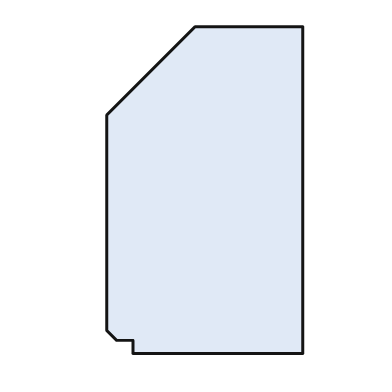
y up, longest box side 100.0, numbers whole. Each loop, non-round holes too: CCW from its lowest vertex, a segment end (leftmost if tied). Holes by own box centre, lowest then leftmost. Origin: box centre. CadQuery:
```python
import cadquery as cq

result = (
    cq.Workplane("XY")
    .moveTo(-22.0, -50.0)
    .lineTo(30.0, -50.0)
    .lineTo(30.0, 50.0)
    .lineTo(-3.0, 50.0)
    .lineTo(-30.0, 23.0)
    .lineTo(-30.0, -43.0)
    .lineTo(-27.0, -46.0)
    .lineTo(-22.0, -46.0)
    .close()
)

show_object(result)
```